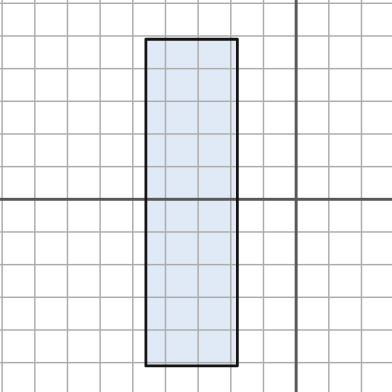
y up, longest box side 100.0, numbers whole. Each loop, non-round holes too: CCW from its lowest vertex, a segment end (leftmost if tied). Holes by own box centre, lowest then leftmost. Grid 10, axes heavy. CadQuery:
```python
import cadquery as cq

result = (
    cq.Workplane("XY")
    .moveTo(-46.0, -51.0)
    .lineTo(-18.0, -51.0)
    .lineTo(-18.0, 49.0)
    .lineTo(-46.0, 49.0)
    .close()
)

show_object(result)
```